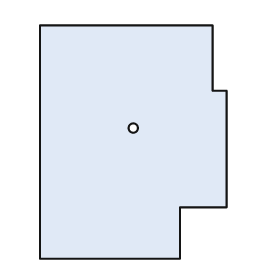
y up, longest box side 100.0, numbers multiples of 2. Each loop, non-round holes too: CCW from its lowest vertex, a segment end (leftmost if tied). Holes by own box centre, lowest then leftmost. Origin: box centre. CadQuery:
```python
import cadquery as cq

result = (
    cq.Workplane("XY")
    .moveTo(-40.0, -50.0)
    .lineTo(20.0, -50.0)
    .lineTo(20.0, -28.0)
    .lineTo(40.0, -28.0)
    .lineTo(40.0, 22.0)
    .lineTo(34.0, 22.0)
    .lineTo(34.0, 50.0)
    .lineTo(-40.0, 50.0)
    .close()
    .moveTo(0.0, 6.0)
    .circle(2.0)
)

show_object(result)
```